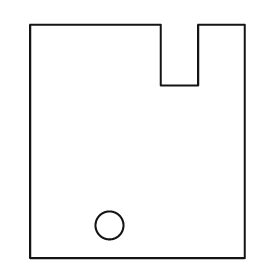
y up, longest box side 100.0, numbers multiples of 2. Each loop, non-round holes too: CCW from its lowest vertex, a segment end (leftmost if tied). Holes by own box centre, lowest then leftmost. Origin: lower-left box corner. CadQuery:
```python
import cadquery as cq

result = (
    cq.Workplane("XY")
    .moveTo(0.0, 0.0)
    .lineTo(92.0, 0.0)
    .lineTo(92.0, 100.0)
    .lineTo(72.0, 100.0)
    .lineTo(72.0, 74.0)
    .lineTo(56.0, 74.0)
    .lineTo(56.0, 100.0)
    .lineTo(0.0, 100.0)
    .close()
    .moveTo(34.0, 14.0)
    .circle(6.0)
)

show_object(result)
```